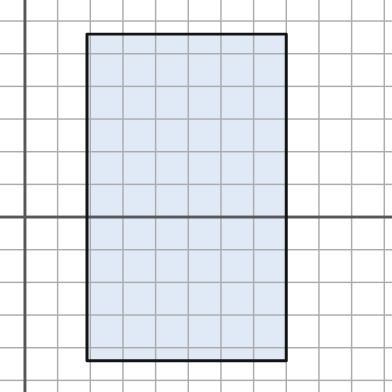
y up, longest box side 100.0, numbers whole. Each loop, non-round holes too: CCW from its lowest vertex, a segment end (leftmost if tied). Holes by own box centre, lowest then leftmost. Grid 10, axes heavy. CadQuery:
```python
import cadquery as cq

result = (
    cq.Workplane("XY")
    .moveTo(19.0, -44.0)
    .lineTo(80.0, -44.0)
    .lineTo(80.0, 56.0)
    .lineTo(19.0, 56.0)
    .close()
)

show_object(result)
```